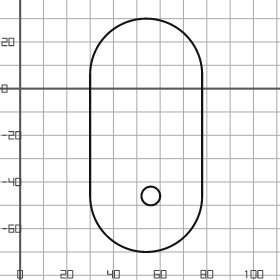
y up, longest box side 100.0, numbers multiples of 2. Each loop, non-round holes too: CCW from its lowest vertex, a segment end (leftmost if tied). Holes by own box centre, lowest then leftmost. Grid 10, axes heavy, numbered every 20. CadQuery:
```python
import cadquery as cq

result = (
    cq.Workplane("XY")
    .moveTo(30.0, -46.0)
    .threePointArc((54.0, -70.0), (78.0, -46.0))
    .lineTo(78.0, 6.0)
    .threePointArc((54.0, 30.0), (30.0, 6.0))
    .close()
    .moveTo(56.0, -46.0)
    .circle(4.0)
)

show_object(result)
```